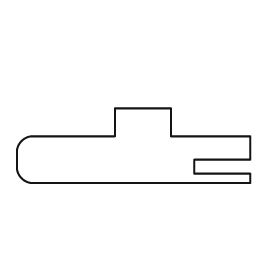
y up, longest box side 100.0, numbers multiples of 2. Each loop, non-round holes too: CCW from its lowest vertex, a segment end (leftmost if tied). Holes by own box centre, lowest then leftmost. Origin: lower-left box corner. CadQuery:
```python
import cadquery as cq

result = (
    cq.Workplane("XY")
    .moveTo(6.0, 0.0)
    .lineTo(100.0, 0.0)
    .lineTo(100.0, 4.0)
    .lineTo(76.0, 4.0)
    .lineTo(76.0, 10.0)
    .lineTo(100.0, 10.0)
    .lineTo(100.0, 20.0)
    .lineTo(66.0, 20.0)
    .lineTo(66.0, 32.0)
    .lineTo(42.0, 32.0)
    .lineTo(42.0, 20.0)
    .lineTo(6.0, 20.0)
    .threePointArc((2.0, 18.0), (0.0, 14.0))
    .lineTo(0.0, 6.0)
    .threePointArc((2.0, 2.0), (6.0, 0.0))
    .close()
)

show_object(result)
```